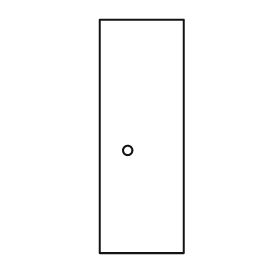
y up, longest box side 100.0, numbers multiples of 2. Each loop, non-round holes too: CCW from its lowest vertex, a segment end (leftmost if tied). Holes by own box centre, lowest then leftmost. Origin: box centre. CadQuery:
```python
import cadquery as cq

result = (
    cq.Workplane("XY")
    .moveTo(-18.0, -50.0)
    .lineTo(18.0, -50.0)
    .lineTo(18.0, 50.0)
    .lineTo(-18.0, 50.0)
    .close()
    .moveTo(-6.0, -6.0)
    .circle(2.0)
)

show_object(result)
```